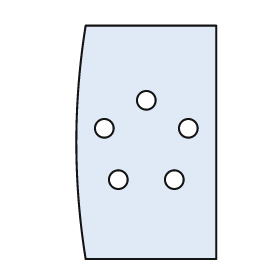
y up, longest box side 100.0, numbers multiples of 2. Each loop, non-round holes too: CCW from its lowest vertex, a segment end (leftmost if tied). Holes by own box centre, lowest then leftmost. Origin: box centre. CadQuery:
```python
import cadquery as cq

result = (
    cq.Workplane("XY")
    .moveTo(-26.0, -50.0)
    .lineTo(30.0, -50.0)
    .lineTo(30.0, 50.0)
    .lineTo(-26.0, 50.0)
    .threePointArc((-30.0, 0.0), (-26.0, -50.0))
    .close()
    .moveTo(-12.0, -16.0)
    .circle(4.0)
    .moveTo(12.0, -16.0)
    .circle(4.0)
    .moveTo(-18.0, 6.0)
    .circle(4.0)
    .moveTo(18.0, 6.0)
    .circle(4.0)
    .moveTo(0.0, 18.0)
    .circle(4.0)
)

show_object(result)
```